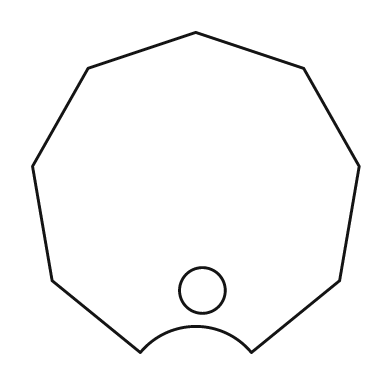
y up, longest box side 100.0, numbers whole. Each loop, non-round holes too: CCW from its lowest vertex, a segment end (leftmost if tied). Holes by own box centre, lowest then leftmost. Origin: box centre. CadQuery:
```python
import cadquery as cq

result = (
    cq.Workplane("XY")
    .moveTo(-17.0, -49.0)
    .threePointArc((0.0, -41.0), (17.0, -49.0))
    .lineTo(44.0, -27.0)
    .lineTo(50.0, 8.0)
    .lineTo(33.0, 38.0)
    .lineTo(0.0, 49.0)
    .lineTo(-33.0, 38.0)
    .lineTo(-50.0, 8.0)
    .lineTo(-44.0, -27.0)
    .close()
    .moveTo(2.0, -30.0)
    .circle(7.0)
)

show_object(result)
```